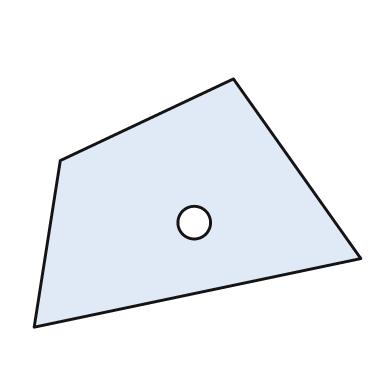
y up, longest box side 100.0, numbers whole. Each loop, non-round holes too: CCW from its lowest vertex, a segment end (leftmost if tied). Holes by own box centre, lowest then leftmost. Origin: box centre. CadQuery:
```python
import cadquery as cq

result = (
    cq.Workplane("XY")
    .moveTo(-50.0, -38.0)
    .lineTo(50.0, -17.0)
    .lineTo(11.0, 38.0)
    .lineTo(-42.0, 13.0)
    .close()
    .moveTo(-1.0, -6.0)
    .circle(5.0)
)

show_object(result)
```